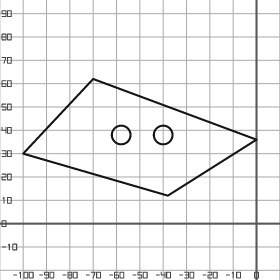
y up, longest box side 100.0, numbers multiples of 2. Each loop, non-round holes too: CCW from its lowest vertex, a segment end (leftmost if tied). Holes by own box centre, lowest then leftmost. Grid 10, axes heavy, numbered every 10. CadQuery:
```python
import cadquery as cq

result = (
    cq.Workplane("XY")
    .moveTo(-38.0, 12.0)
    .lineTo(0.0, 36.0)
    .lineTo(-70.0, 62.0)
    .lineTo(-100.0, 30.0)
    .close()
    .moveTo(-58.0, 38.0)
    .circle(4.0)
    .moveTo(-40.0, 38.0)
    .circle(4.0)
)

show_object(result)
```